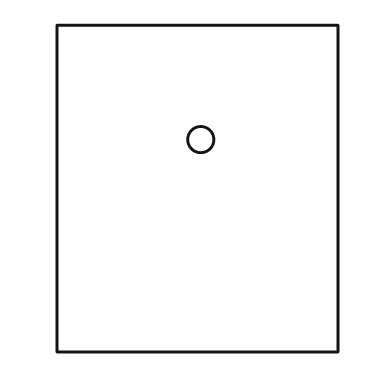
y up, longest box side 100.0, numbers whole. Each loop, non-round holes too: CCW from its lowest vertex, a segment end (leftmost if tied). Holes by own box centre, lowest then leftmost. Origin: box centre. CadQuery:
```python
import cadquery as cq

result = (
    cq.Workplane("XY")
    .moveTo(-43.0, -50.0)
    .lineTo(43.0, -50.0)
    .lineTo(43.0, 50.0)
    .lineTo(-43.0, 50.0)
    .close()
    .moveTo(1.0, 15.0)
    .circle(4.0)
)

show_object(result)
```